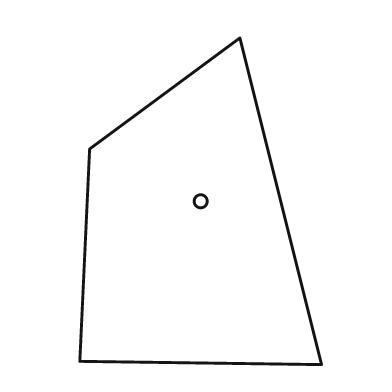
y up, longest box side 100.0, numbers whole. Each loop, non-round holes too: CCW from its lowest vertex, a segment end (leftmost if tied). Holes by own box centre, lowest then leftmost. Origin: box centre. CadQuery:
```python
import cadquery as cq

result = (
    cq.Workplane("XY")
    .moveTo(37.0, -50.0)
    .lineTo(12.0, 50.0)
    .lineTo(-34.0, 16.0)
    .lineTo(-37.0, -49.0)
    .close()
    .moveTo(0.0, 0.0)
    .circle(2.0)
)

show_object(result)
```